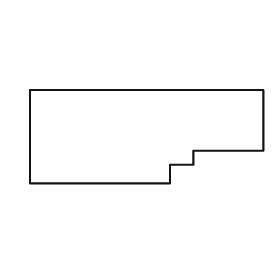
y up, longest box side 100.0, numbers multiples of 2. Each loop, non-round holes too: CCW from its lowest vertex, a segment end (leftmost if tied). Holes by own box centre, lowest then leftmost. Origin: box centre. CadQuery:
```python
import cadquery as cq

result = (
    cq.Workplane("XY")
    .moveTo(-50.0, -20.0)
    .lineTo(10.0, -20.0)
    .lineTo(10.0, -12.0)
    .lineTo(20.0, -12.0)
    .lineTo(20.0, -6.0)
    .lineTo(50.0, -6.0)
    .lineTo(50.0, 20.0)
    .lineTo(-50.0, 20.0)
    .close()
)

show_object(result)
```